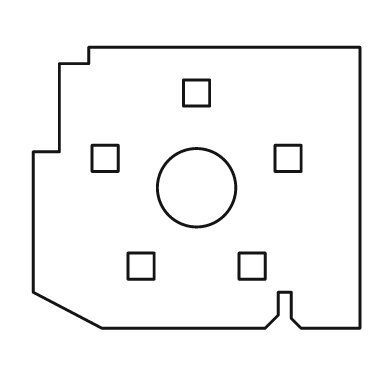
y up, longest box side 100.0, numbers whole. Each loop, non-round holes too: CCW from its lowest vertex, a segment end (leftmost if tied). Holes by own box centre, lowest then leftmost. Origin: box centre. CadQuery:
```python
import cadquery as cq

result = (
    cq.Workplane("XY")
    .moveTo(-29.0, -43.0)
    .lineTo(21.0, -43.0)
    .lineTo(25.0, -39.0)
    .lineTo(25.0, -32.0)
    .lineTo(29.0, -32.0)
    .lineTo(29.0, -40.0)
    .lineTo(32.0, -43.0)
    .lineTo(50.0, -43.0)
    .lineTo(50.0, 43.0)
    .lineTo(-33.0, 43.0)
    .lineTo(-33.0, 38.0)
    .lineTo(-42.0, 38.0)
    .lineTo(-42.0, 11.0)
    .lineTo(-50.0, 11.0)
    .lineTo(-50.0, -32.0)
    .close()
    .moveTo(-21.0, -28.0)
    .lineTo(-13.0, -28.0)
    .lineTo(-13.0, -20.0)
    .lineTo(-21.0, -20.0)
    .close()
    .moveTo(13.0, -28.0)
    .lineTo(21.0, -28.0)
    .lineTo(21.0, -20.0)
    .lineTo(13.0, -20.0)
    .close()
    .moveTo(0.0, 0.0)
    .circle(12.0)
    .moveTo(-32.0, 5.0)
    .lineTo(-24.0, 5.0)
    .lineTo(-24.0, 13.0)
    .lineTo(-32.0, 13.0)
    .close()
    .moveTo(24.0, 5.0)
    .lineTo(32.0, 5.0)
    .lineTo(32.0, 13.0)
    .lineTo(24.0, 13.0)
    .close()
    .moveTo(-4.0, 25.0)
    .lineTo(4.0, 25.0)
    .lineTo(4.0, 33.0)
    .lineTo(-4.0, 33.0)
    .close()
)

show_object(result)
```